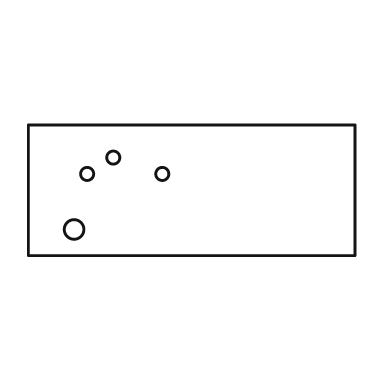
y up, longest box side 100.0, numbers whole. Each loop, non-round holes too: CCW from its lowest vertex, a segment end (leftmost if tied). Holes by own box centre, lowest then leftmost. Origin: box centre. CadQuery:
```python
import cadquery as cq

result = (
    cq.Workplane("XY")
    .moveTo(-50.0, -20.0)
    .lineTo(50.0, -20.0)
    .lineTo(50.0, 20.0)
    .lineTo(-50.0, 20.0)
    .close()
    .moveTo(-36.0, -12.0)
    .circle(3.0)
    .moveTo(-32.0, 5.0)
    .circle(2.0)
    .moveTo(-9.0, 5.0)
    .circle(2.0)
    .moveTo(-24.0, 10.0)
    .circle(2.0)
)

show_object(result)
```